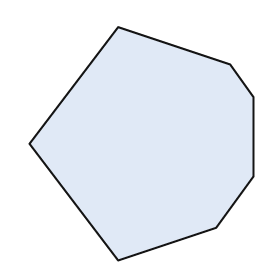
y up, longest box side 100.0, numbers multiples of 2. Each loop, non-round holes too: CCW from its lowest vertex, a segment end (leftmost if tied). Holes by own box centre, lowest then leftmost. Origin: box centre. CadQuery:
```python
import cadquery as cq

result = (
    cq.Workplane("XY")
    .moveTo(-10.0, -50.0)
    .lineTo(32.0, -36.0)
    .lineTo(48.0, -14.0)
    .lineTo(48.0, 20.0)
    .lineTo(38.0, 34.0)
    .lineTo(-10.0, 50.0)
    .lineTo(-48.0, 0.0)
    .close()
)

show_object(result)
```